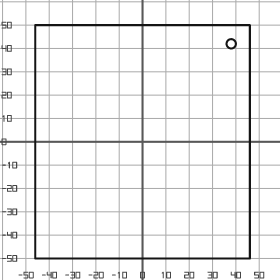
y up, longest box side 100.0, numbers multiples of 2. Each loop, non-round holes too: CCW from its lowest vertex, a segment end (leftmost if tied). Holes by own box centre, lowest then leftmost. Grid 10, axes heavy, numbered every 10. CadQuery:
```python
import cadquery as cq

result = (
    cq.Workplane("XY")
    .moveTo(-46.0, -50.0)
    .lineTo(46.0, -50.0)
    .lineTo(46.0, 50.0)
    .lineTo(-46.0, 50.0)
    .close()
    .moveTo(38.0, 42.0)
    .circle(2.0)
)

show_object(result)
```